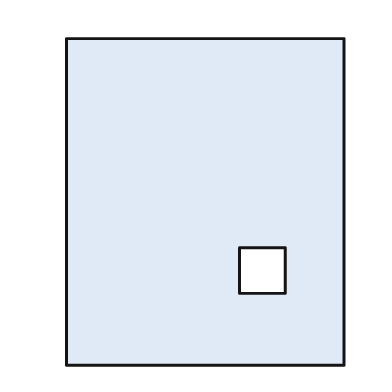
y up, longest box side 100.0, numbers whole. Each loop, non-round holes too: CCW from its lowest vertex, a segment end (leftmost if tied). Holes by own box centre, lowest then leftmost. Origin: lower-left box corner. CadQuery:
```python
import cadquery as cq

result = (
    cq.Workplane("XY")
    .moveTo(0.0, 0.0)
    .lineTo(85.0, 0.0)
    .lineTo(85.0, 100.0)
    .lineTo(0.0, 100.0)
    .close()
    .moveTo(53.0, 22.0)
    .lineTo(67.0, 22.0)
    .lineTo(67.0, 36.0)
    .lineTo(53.0, 36.0)
    .close()
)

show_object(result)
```